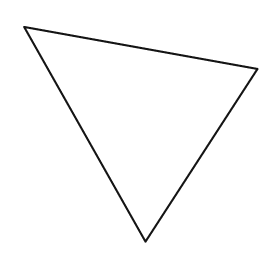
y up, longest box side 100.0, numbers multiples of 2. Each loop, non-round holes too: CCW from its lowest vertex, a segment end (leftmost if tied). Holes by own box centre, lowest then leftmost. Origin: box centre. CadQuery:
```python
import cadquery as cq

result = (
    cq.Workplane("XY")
    .moveTo(2.0, -46.0)
    .lineTo(50.0, 28.0)
    .lineTo(-50.0, 46.0)
    .close()
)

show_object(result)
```